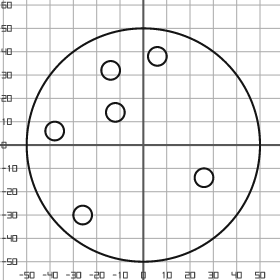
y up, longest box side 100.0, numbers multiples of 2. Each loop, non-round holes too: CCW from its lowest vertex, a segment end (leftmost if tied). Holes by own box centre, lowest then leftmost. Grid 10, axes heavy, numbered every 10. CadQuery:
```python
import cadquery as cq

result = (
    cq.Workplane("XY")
    .moveTo(0.0, 0.0)
    .circle(50.0)
    .moveTo(-26.0, -30.0)
    .circle(4.0)
    .moveTo(26.0, -14.0)
    .circle(4.0)
    .moveTo(-38.0, 6.0)
    .circle(4.0)
    .moveTo(-12.0, 14.0)
    .circle(4.0)
    .moveTo(-14.0, 32.0)
    .circle(4.0)
    .moveTo(6.0, 38.0)
    .circle(4.0)
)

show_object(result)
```